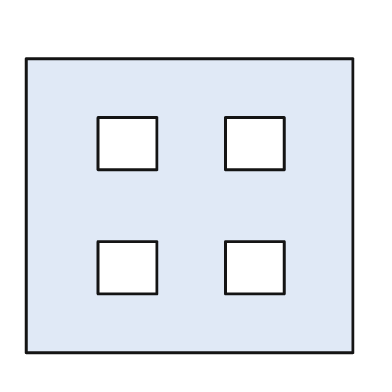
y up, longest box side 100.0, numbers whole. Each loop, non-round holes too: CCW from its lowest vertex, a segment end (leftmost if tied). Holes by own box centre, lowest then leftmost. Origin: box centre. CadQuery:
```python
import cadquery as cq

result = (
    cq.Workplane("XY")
    .moveTo(-50.0, -45.0)
    .lineTo(50.0, -45.0)
    .lineTo(50.0, 45.0)
    .lineTo(-50.0, 45.0)
    .close()
    .moveTo(-28.0, -27.0)
    .lineTo(-10.0, -27.0)
    .lineTo(-10.0, -11.0)
    .lineTo(-28.0, -11.0)
    .close()
    .moveTo(11.0, -27.0)
    .lineTo(29.0, -27.0)
    .lineTo(29.0, -11.0)
    .lineTo(11.0, -11.0)
    .close()
    .moveTo(-28.0, 11.0)
    .lineTo(-10.0, 11.0)
    .lineTo(-10.0, 27.0)
    .lineTo(-28.0, 27.0)
    .close()
    .moveTo(11.0, 11.0)
    .lineTo(29.0, 11.0)
    .lineTo(29.0, 27.0)
    .lineTo(11.0, 27.0)
    .close()
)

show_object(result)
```